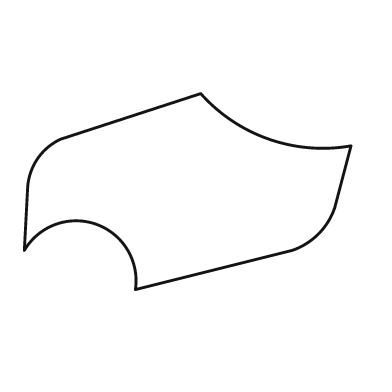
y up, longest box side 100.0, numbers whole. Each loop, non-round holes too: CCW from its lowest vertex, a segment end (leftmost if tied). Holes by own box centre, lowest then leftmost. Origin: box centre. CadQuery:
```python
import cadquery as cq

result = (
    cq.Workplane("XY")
    .moveTo(-16.0, -30.0)
    .lineTo(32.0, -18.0)
    .threePointArc((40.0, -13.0), (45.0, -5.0))
    .lineTo(50.0, 14.0)
    .threePointArc((25.0, 16.0), (4.0, 30.0))
    .lineTo(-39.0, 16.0)
    .threePointArc((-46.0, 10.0), (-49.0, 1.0))
    .lineTo(-50.0, -18.0)
    .threePointArc((-28.0, -10.0), (-16.0, -30.0))
    .close()
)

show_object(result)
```